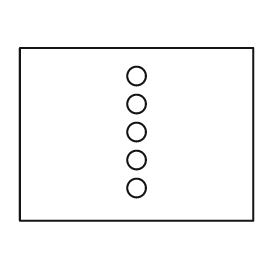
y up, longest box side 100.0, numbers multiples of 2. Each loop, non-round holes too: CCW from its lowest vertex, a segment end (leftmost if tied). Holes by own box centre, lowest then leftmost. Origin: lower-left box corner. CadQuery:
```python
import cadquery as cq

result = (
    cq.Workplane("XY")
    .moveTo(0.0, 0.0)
    .lineTo(100.0, 0.0)
    .lineTo(100.0, 74.0)
    .lineTo(0.0, 74.0)
    .close()
    .moveTo(50.0, 14.0)
    .circle(4.0)
    .moveTo(50.0, 26.0)
    .circle(4.0)
    .moveTo(50.0, 38.0)
    .circle(4.0)
    .moveTo(50.0, 50.0)
    .circle(4.0)
    .moveTo(50.0, 62.0)
    .circle(4.0)
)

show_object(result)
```